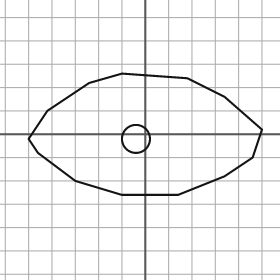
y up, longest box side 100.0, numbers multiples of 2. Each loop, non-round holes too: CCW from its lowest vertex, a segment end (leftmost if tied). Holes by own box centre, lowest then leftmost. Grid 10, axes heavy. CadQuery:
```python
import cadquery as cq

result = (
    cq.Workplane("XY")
    .moveTo(-10.0, -26.0)
    .lineTo(14.0, -26.0)
    .lineTo(34.0, -18.0)
    .lineTo(46.0, -10.0)
    .lineTo(50.0, 2.0)
    .lineTo(34.0, 16.0)
    .lineTo(18.0, 24.0)
    .lineTo(-10.0, 26.0)
    .lineTo(-24.0, 22.0)
    .lineTo(-42.0, 10.0)
    .lineTo(-50.0, -2.0)
    .lineTo(-46.0, -8.0)
    .lineTo(-30.0, -20.0)
    .close()
    .moveTo(-4.0, -2.0)
    .circle(6.0)
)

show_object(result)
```